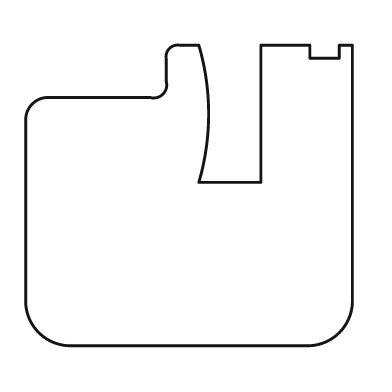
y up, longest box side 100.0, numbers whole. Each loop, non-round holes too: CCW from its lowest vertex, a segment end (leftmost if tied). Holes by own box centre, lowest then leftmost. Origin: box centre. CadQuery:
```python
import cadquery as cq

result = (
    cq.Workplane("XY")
    .moveTo(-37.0, -46.0)
    .lineTo(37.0, -46.0)
    .threePointArc((46.0, -42.0), (50.0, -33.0))
    .lineTo(50.0, 46.0)
    .lineTo(46.0, 46.0)
    .lineTo(46.0, 42.0)
    .lineTo(37.0, 42.0)
    .lineTo(37.0, 46.0)
    .lineTo(22.0, 46.0)
    .lineTo(22.0, 4.0)
    .lineTo(3.0, 4.0)
    .threePointArc((6.0, 25.0), (3.0, 46.0))
    .lineTo(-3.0, 46.0)
    .threePointArc((-6.0, 45.0), (-7.0, 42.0))
    .lineTo(-7.0, 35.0)
    .threePointArc((-8.0, 31.0), (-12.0, 30.0))
    .lineTo(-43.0, 30.0)
    .threePointArc((-48.0, 28.0), (-50.0, 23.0))
    .lineTo(-50.0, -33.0)
    .threePointArc((-46.0, -42.0), (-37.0, -46.0))
    .close()
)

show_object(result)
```